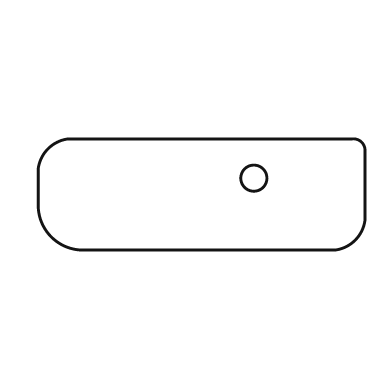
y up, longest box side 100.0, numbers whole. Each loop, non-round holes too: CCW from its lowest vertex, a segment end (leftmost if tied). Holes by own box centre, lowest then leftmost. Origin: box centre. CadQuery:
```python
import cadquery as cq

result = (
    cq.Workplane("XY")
    .moveTo(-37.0, -17.0)
    .lineTo(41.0, -17.0)
    .threePointArc((47.0, -14.0), (50.0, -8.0))
    .lineTo(50.0, 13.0)
    .threePointArc((49.0, 16.0), (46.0, 17.0))
    .lineTo(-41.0, 17.0)
    .threePointArc((-47.0, 14.0), (-50.0, 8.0))
    .lineTo(-50.0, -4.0)
    .threePointArc((-46.0, -13.0), (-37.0, -17.0))
    .close()
    .moveTo(16.0, 5.0)
    .circle(4.0)
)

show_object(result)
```